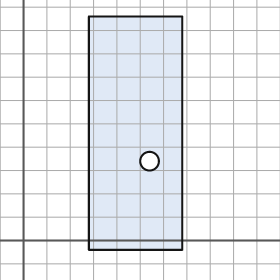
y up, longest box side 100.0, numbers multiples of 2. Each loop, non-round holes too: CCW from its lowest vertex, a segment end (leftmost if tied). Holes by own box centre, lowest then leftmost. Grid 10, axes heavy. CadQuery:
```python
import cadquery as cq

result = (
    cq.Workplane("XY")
    .moveTo(28.0, -4.0)
    .lineTo(68.0, -4.0)
    .lineTo(68.0, 96.0)
    .lineTo(28.0, 96.0)
    .close()
    .moveTo(54.0, 34.0)
    .circle(4.0)
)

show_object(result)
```